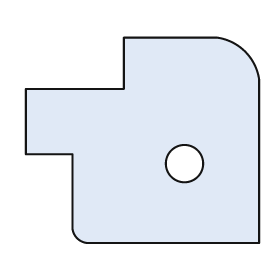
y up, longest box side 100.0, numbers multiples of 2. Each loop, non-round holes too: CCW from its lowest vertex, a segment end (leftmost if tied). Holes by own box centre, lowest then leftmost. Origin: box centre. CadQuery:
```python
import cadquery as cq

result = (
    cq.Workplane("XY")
    .moveTo(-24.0, -44.0)
    .lineTo(50.0, -44.0)
    .lineTo(50.0, 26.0)
    .threePointArc((44.0, 38.0), (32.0, 44.0))
    .lineTo(-8.0, 44.0)
    .lineTo(-8.0, 22.0)
    .lineTo(-50.0, 22.0)
    .lineTo(-50.0, -6.0)
    .lineTo(-30.0, -6.0)
    .lineTo(-30.0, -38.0)
    .threePointArc((-28.0, -42.0), (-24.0, -44.0))
    .close()
    .moveTo(18.0, -10.0)
    .circle(8.0)
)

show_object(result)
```